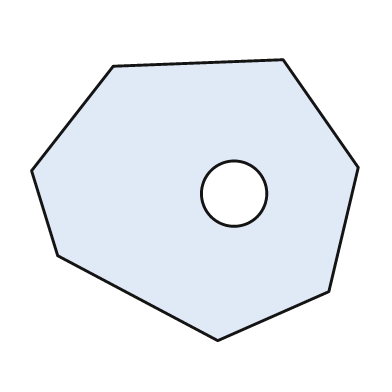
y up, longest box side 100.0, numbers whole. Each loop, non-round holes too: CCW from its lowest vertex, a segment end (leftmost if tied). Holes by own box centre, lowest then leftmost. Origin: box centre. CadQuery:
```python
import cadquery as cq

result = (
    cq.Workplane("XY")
    .moveTo(7.0, -43.0)
    .lineTo(41.0, -28.0)
    .lineTo(50.0, 10.0)
    .lineTo(27.0, 43.0)
    .lineTo(-25.0, 41.0)
    .lineTo(-50.0, 9.0)
    .lineTo(-42.0, -17.0)
    .close()
    .moveTo(12.0, 2.0)
    .circle(10.0)
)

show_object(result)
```